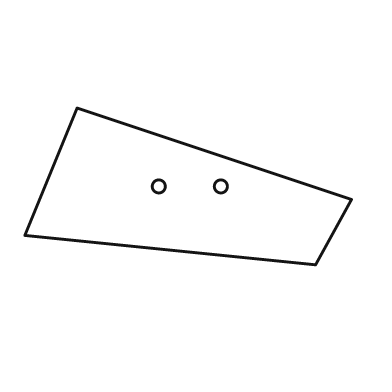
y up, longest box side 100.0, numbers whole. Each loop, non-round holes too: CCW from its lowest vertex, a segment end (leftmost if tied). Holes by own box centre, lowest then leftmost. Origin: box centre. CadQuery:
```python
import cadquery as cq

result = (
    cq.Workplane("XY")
    .moveTo(39.0, -24.0)
    .lineTo(50.0, -4.0)
    .lineTo(-34.0, 24.0)
    .lineTo(-50.0, -15.0)
    .close()
    .moveTo(-9.0, 0.0)
    .circle(2.0)
    .moveTo(10.0, 0.0)
    .circle(2.0)
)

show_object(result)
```